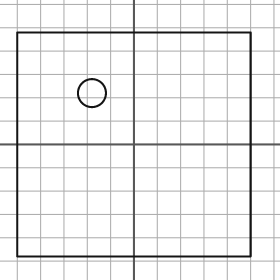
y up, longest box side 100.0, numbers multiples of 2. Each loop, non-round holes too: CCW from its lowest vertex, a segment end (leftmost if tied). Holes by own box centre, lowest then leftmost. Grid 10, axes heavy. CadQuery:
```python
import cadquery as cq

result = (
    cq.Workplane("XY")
    .moveTo(-50.0, -48.0)
    .lineTo(50.0, -48.0)
    .lineTo(50.0, 48.0)
    .lineTo(-50.0, 48.0)
    .close()
    .moveTo(-18.0, 22.0)
    .circle(6.0)
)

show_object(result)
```